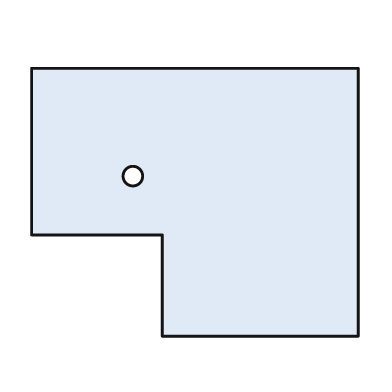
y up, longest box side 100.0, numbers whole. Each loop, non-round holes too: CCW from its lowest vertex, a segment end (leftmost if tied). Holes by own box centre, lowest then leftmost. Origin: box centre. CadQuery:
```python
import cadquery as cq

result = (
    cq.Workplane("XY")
    .moveTo(-10.0, -41.0)
    .lineTo(50.0, -41.0)
    .lineTo(50.0, 41.0)
    .lineTo(-50.0, 41.0)
    .lineTo(-50.0, -10.0)
    .lineTo(-10.0, -10.0)
    .close()
    .moveTo(-19.0, 8.0)
    .circle(3.0)
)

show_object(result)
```